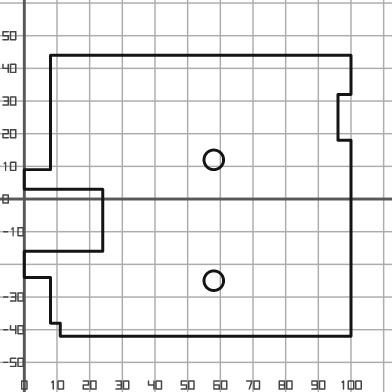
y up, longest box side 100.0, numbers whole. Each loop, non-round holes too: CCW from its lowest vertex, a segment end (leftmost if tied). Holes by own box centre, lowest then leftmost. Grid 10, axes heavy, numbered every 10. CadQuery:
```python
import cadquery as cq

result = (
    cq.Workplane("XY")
    .moveTo(11.0, -42.0)
    .lineTo(100.0, -42.0)
    .lineTo(100.0, 18.0)
    .lineTo(96.0, 18.0)
    .lineTo(96.0, 32.0)
    .lineTo(100.0, 32.0)
    .lineTo(100.0, 44.0)
    .lineTo(8.0, 44.0)
    .lineTo(8.0, 9.0)
    .lineTo(0.0, 9.0)
    .lineTo(0.0, 3.0)
    .lineTo(24.0, 3.0)
    .lineTo(24.0, -16.0)
    .lineTo(0.0, -16.0)
    .lineTo(0.0, -24.0)
    .lineTo(8.0, -24.0)
    .lineTo(8.0, -38.0)
    .lineTo(11.0, -38.0)
    .close()
    .moveTo(58.0, -25.0)
    .circle(3.0)
    .moveTo(58.0, 12.0)
    .circle(3.0)
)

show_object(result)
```